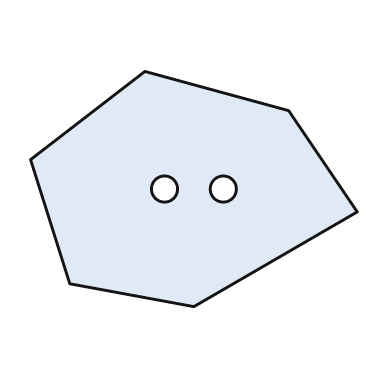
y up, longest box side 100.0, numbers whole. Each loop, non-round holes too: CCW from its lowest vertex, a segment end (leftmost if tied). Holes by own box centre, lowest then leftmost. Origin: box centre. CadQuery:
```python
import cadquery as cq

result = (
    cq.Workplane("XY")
    .moveTo(0.0, -36.0)
    .lineTo(50.0, -7.0)
    .lineTo(29.0, 24.0)
    .lineTo(-15.0, 36.0)
    .lineTo(-50.0, 9.0)
    .lineTo(-38.0, -29.0)
    .close()
    .moveTo(-9.0, 0.0)
    .circle(4.0)
    .moveTo(9.0, 0.0)
    .circle(4.0)
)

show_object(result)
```